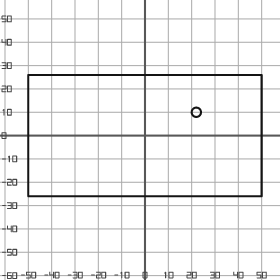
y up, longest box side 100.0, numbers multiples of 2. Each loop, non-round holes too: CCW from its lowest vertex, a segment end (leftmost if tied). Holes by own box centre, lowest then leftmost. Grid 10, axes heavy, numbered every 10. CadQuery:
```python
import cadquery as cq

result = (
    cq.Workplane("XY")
    .moveTo(-50.0, -26.0)
    .lineTo(50.0, -26.0)
    .lineTo(50.0, 26.0)
    .lineTo(-50.0, 26.0)
    .close()
    .moveTo(22.0, 10.0)
    .circle(2.0)
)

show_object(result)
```